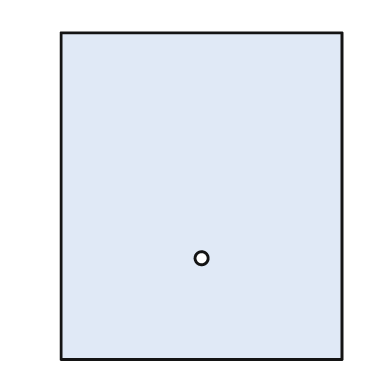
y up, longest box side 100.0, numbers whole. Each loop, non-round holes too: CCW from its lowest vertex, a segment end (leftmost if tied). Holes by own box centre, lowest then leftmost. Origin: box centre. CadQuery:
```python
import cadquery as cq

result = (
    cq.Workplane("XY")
    .moveTo(-43.0, -50.0)
    .lineTo(43.0, -50.0)
    .lineTo(43.0, 50.0)
    .lineTo(-43.0, 50.0)
    .close()
    .moveTo(0.0, -19.0)
    .circle(2.0)
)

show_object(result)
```